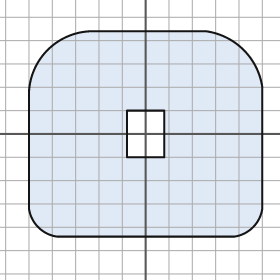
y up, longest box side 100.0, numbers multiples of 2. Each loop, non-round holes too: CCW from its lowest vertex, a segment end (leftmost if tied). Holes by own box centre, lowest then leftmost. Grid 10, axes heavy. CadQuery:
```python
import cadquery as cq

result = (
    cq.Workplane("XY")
    .moveTo(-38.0, -44.0)
    .lineTo(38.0, -44.0)
    .threePointArc((46.0, -40.0), (50.0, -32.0))
    .lineTo(50.0, 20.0)
    .threePointArc((42.0, 36.0), (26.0, 44.0))
    .lineTo(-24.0, 44.0)
    .threePointArc((-42.0, 36.0), (-50.0, 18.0))
    .lineTo(-50.0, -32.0)
    .threePointArc((-46.0, -40.0), (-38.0, -44.0))
    .close()
    .moveTo(-8.0, -10.0)
    .lineTo(8.0, -10.0)
    .lineTo(8.0, 10.0)
    .lineTo(-8.0, 10.0)
    .close()
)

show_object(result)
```